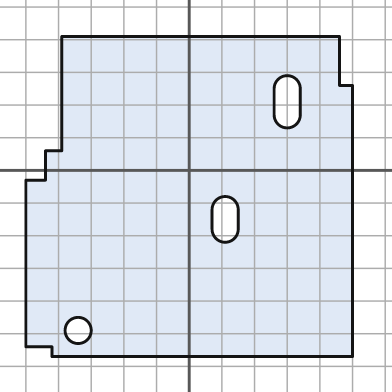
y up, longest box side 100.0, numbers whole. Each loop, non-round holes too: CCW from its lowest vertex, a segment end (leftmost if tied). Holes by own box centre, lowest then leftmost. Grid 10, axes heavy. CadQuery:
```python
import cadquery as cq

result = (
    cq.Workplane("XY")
    .moveTo(-42.0, -57.0)
    .lineTo(50.0, -57.0)
    .lineTo(50.0, 26.0)
    .lineTo(46.0, 26.0)
    .lineTo(46.0, 41.0)
    .lineTo(-39.0, 41.0)
    .lineTo(-39.0, 6.0)
    .lineTo(-44.0, 6.0)
    .lineTo(-44.0, -3.0)
    .lineTo(-50.0, -3.0)
    .lineTo(-50.0, -54.0)
    .lineTo(-42.0, -54.0)
    .close()
    .moveTo(-34.0, -49.0)
    .circle(4.0)
    .moveTo(7.0, -18.0)
    .threePointArc((11.0, -22.0), (15.0, -18.0))
    .lineTo(15.0, -12.0)
    .threePointArc((11.0, -8.0), (7.0, -12.0))
    .close()
    .moveTo(26.0, 17.0)
    .threePointArc((30.0, 13.0), (34.0, 17.0))
    .lineTo(34.0, 25.0)
    .threePointArc((30.0, 29.0), (26.0, 25.0))
    .close()
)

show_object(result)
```